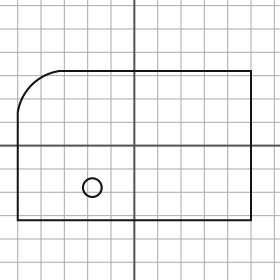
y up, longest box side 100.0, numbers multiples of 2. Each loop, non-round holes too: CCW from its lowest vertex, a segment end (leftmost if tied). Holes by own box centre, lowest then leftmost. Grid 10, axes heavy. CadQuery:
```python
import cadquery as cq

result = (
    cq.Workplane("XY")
    .moveTo(-50.0, -32.0)
    .lineTo(50.0, -32.0)
    .lineTo(50.0, 32.0)
    .lineTo(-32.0, 32.0)
    .threePointArc((-44.0, 26.0), (-50.0, 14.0))
    .close()
    .moveTo(-18.0, -18.0)
    .circle(4.0)
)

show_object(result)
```